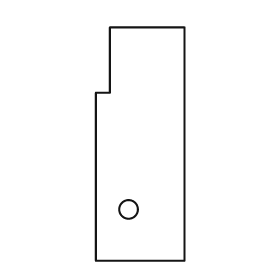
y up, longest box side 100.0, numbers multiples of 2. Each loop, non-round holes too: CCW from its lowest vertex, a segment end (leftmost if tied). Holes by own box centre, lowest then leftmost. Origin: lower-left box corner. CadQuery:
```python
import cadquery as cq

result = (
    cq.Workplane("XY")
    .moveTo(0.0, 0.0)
    .lineTo(38.0, 0.0)
    .lineTo(38.0, 100.0)
    .lineTo(6.0, 100.0)
    .lineTo(6.0, 72.0)
    .lineTo(0.0, 72.0)
    .close()
    .moveTo(14.0, 22.0)
    .circle(4.0)
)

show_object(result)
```